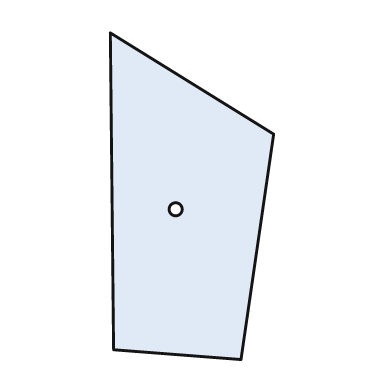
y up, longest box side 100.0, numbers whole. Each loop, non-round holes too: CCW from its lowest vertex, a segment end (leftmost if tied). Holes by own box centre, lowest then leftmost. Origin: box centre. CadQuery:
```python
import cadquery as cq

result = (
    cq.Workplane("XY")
    .moveTo(15.0, -50.0)
    .lineTo(25.0, 19.0)
    .lineTo(-25.0, 50.0)
    .lineTo(-24.0, -47.0)
    .close()
    .moveTo(-5.0, -4.0)
    .circle(2.0)
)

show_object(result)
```